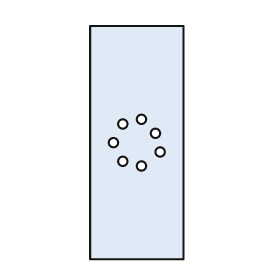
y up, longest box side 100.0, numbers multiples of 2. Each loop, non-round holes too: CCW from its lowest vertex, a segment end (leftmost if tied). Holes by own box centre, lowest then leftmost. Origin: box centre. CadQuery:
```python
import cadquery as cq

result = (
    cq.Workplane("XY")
    .moveTo(-20.0, -50.0)
    .lineTo(20.0, -50.0)
    .lineTo(20.0, 50.0)
    .lineTo(-20.0, 50.0)
    .close()
    .moveTo(2.0, -10.0)
    .circle(2.0)
    .moveTo(-6.0, -8.0)
    .circle(2.0)
    .moveTo(10.0, -4.0)
    .circle(2.0)
    .moveTo(-10.0, 0.0)
    .circle(2.0)
    .moveTo(8.0, 4.0)
    .circle(2.0)
    .moveTo(-6.0, 8.0)
    .circle(2.0)
    .moveTo(2.0, 10.0)
    .circle(2.0)
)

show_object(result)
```